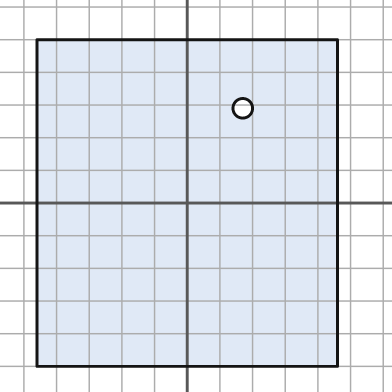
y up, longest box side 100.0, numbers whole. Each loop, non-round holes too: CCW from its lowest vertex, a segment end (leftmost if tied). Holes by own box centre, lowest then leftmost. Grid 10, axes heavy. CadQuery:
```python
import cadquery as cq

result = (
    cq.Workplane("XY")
    .moveTo(-46.0, -50.0)
    .lineTo(46.0, -50.0)
    .lineTo(46.0, 50.0)
    .lineTo(-46.0, 50.0)
    .close()
    .moveTo(17.0, 29.0)
    .circle(3.0)
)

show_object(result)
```